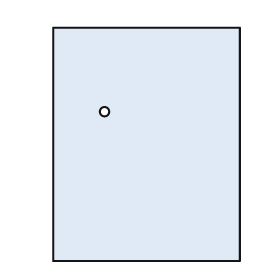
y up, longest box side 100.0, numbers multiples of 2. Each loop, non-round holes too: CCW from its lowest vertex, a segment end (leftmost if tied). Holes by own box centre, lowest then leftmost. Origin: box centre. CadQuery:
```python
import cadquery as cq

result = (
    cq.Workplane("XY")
    .moveTo(-40.0, -50.0)
    .lineTo(40.0, -50.0)
    .lineTo(40.0, 50.0)
    .lineTo(-40.0, 50.0)
    .close()
    .moveTo(-18.0, 14.0)
    .circle(2.0)
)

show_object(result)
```